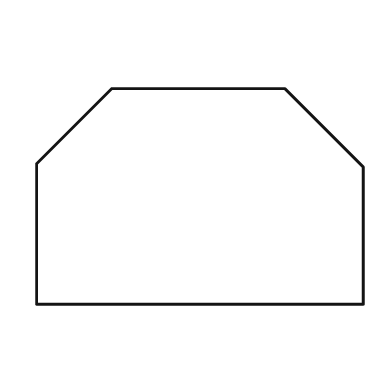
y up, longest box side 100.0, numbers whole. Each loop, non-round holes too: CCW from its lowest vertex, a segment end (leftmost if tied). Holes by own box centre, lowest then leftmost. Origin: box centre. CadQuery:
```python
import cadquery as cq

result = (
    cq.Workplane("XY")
    .moveTo(-50.0, -33.0)
    .lineTo(50.0, -33.0)
    .lineTo(50.0, 9.0)
    .lineTo(26.0, 33.0)
    .lineTo(-27.0, 33.0)
    .lineTo(-50.0, 10.0)
    .close()
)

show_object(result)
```